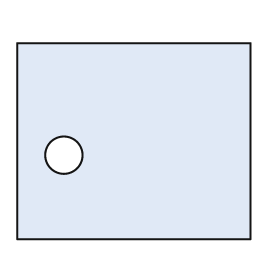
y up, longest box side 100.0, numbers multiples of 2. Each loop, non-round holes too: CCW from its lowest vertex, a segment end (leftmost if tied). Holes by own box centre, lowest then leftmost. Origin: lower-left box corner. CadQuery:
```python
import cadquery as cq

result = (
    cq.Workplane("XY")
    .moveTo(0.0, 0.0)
    .lineTo(100.0, 0.0)
    .lineTo(100.0, 84.0)
    .lineTo(0.0, 84.0)
    .close()
    .moveTo(20.0, 36.0)
    .circle(8.0)
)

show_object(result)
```